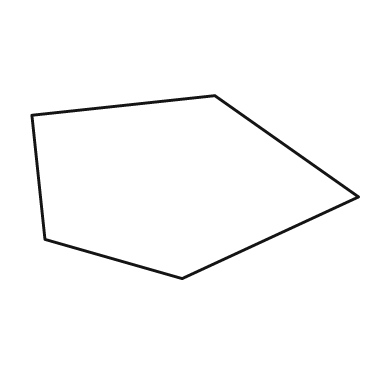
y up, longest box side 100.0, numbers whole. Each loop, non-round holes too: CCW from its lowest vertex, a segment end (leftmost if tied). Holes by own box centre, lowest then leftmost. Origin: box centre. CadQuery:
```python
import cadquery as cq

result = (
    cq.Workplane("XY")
    .moveTo(-4.0, -28.0)
    .lineTo(50.0, -3.0)
    .lineTo(6.0, 28.0)
    .lineTo(-50.0, 22.0)
    .lineTo(-46.0, -16.0)
    .close()
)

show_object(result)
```